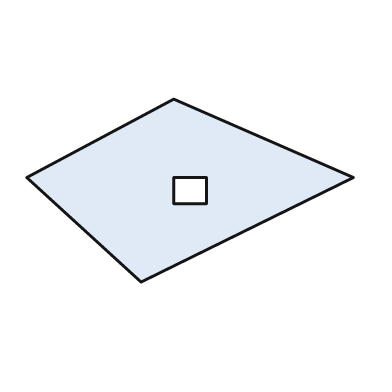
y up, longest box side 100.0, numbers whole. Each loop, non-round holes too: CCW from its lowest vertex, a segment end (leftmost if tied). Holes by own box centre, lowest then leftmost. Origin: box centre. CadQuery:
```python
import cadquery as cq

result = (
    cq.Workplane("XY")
    .moveTo(-15.0, -28.0)
    .lineTo(50.0, 4.0)
    .lineTo(-5.0, 28.0)
    .lineTo(-50.0, 4.0)
    .close()
    .moveTo(-5.0, -4.0)
    .lineTo(5.0, -4.0)
    .lineTo(5.0, 4.0)
    .lineTo(-5.0, 4.0)
    .close()
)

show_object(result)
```